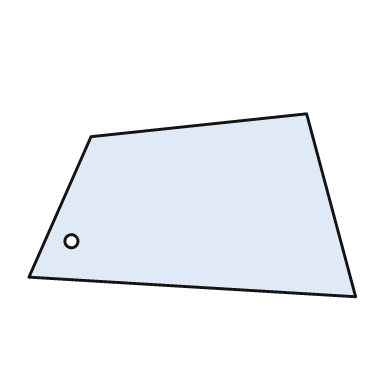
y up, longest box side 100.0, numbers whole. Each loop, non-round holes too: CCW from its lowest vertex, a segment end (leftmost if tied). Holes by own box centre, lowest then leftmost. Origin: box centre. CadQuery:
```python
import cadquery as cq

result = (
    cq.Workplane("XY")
    .moveTo(50.0, -28.0)
    .lineTo(35.0, 28.0)
    .lineTo(-31.0, 21.0)
    .lineTo(-50.0, -22.0)
    .close()
    .moveTo(-37.0, -11.0)
    .circle(2.0)
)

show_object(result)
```